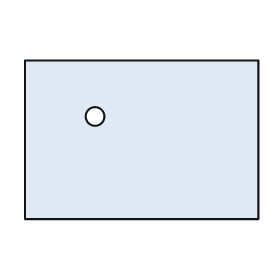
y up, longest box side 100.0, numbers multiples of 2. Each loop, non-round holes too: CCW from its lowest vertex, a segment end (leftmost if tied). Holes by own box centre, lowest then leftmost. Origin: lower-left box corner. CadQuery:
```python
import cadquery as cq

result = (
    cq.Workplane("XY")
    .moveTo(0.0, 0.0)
    .lineTo(100.0, 0.0)
    .lineTo(100.0, 68.0)
    .lineTo(0.0, 68.0)
    .close()
    .moveTo(30.0, 44.0)
    .circle(4.0)
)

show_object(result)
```